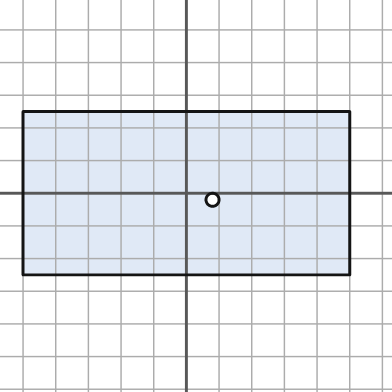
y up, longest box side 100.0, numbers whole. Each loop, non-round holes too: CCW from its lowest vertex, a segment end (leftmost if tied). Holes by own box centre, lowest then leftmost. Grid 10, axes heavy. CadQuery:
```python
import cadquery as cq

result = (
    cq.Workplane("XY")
    .moveTo(-50.0, -25.0)
    .lineTo(50.0, -25.0)
    .lineTo(50.0, 25.0)
    .lineTo(-50.0, 25.0)
    .close()
    .moveTo(8.0, -2.0)
    .circle(2.0)
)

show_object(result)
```